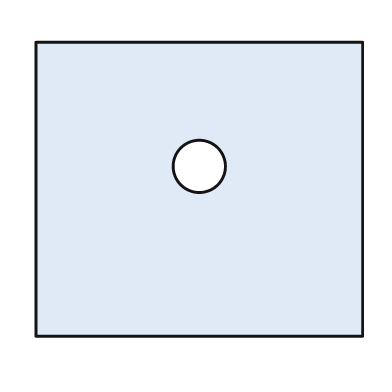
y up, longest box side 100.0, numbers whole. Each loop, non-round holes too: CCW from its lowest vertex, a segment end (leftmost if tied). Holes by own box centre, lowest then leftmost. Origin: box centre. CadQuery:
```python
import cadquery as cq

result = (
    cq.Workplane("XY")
    .moveTo(-50.0, -45.0)
    .lineTo(50.0, -45.0)
    .lineTo(50.0, 45.0)
    .lineTo(-50.0, 45.0)
    .close()
    .moveTo(0.0, 7.0)
    .circle(8.0)
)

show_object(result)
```